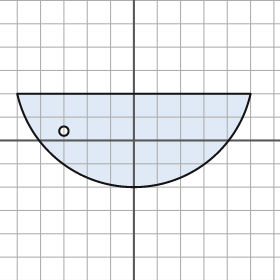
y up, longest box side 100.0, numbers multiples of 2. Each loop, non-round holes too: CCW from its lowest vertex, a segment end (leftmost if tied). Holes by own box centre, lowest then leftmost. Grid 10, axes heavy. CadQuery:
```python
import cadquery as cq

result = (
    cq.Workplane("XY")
    .moveTo(-50.0, 20.0)
    .threePointArc((0.0, -20.0), (50.0, 20.0))
    .close()
    .moveTo(-30.0, 4.0)
    .circle(2.0)
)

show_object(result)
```